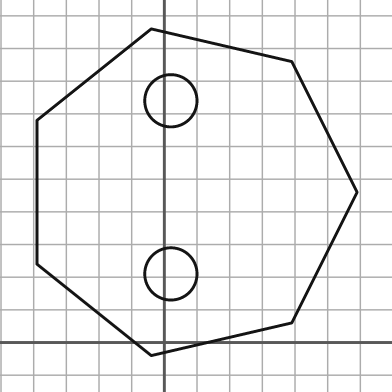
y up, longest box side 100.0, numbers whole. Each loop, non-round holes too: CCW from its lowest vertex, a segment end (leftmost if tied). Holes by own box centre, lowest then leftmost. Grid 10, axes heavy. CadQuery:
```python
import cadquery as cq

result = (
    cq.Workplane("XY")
    .moveTo(-4.0, -4.0)
    .lineTo(39.0, 6.0)
    .lineTo(59.0, 46.0)
    .lineTo(39.0, 86.0)
    .lineTo(-4.0, 96.0)
    .lineTo(-39.0, 68.0)
    .lineTo(-39.0, 24.0)
    .close()
    .moveTo(2.0, 21.0)
    .circle(8.0)
    .moveTo(2.0, 74.0)
    .circle(8.0)
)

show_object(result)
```